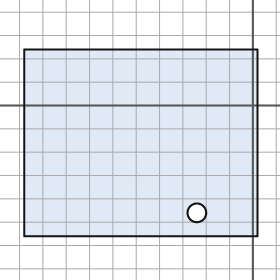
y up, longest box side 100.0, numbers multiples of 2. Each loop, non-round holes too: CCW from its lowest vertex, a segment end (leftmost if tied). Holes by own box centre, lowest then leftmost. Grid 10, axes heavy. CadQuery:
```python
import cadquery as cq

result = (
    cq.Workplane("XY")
    .moveTo(-98.0, -56.0)
    .lineTo(2.0, -56.0)
    .lineTo(2.0, 24.0)
    .lineTo(-98.0, 24.0)
    .close()
    .moveTo(-24.0, -46.0)
    .circle(4.0)
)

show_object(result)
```